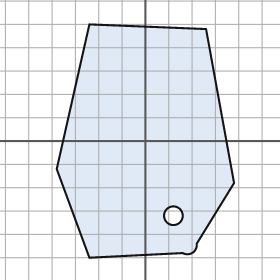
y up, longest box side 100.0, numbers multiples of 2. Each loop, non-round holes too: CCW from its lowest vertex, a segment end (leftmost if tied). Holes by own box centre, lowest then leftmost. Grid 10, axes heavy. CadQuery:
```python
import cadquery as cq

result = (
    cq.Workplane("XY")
    .moveTo(-24.0, -50.0)
    .lineTo(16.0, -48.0)
    .threePointArc((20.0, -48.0), (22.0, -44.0))
    .lineTo(38.0, -18.0)
    .lineTo(26.0, 48.0)
    .lineTo(-24.0, 50.0)
    .lineTo(-38.0, -12.0)
    .close()
    .moveTo(12.0, -32.0)
    .circle(4.0)
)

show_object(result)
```